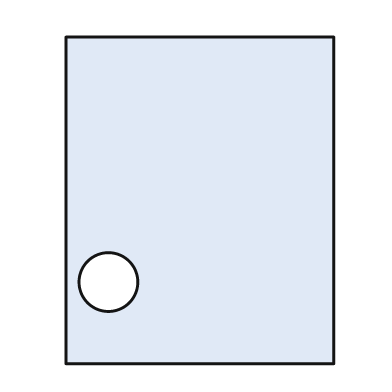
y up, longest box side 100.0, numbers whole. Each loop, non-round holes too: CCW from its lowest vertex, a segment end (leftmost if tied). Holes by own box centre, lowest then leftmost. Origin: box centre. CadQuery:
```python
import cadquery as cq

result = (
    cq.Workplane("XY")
    .moveTo(-41.0, -50.0)
    .lineTo(41.0, -50.0)
    .lineTo(41.0, 50.0)
    .lineTo(-41.0, 50.0)
    .close()
    .moveTo(-28.0, -25.0)
    .circle(9.0)
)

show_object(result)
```